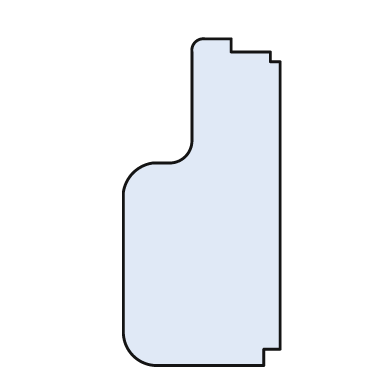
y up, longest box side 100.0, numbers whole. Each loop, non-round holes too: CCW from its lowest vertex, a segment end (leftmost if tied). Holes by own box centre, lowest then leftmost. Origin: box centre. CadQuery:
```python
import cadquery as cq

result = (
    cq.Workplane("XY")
    .moveTo(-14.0, -50.0)
    .lineTo(19.0, -50.0)
    .lineTo(19.0, -45.0)
    .lineTo(24.0, -45.0)
    .lineTo(24.0, 43.0)
    .lineTo(21.0, 43.0)
    .lineTo(21.0, 46.0)
    .lineTo(9.0, 46.0)
    .lineTo(9.0, 50.0)
    .lineTo(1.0, 50.0)
    .threePointArc((-2.0, 49.0), (-3.0, 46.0))
    .lineTo(-3.0, 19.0)
    .threePointArc((-5.0, 14.0), (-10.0, 12.0))
    .lineTo(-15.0, 12.0)
    .threePointArc((-21.0, 9.0), (-24.0, 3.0))
    .lineTo(-24.0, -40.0)
    .threePointArc((-21.0, -47.0), (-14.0, -50.0))
    .close()
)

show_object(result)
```